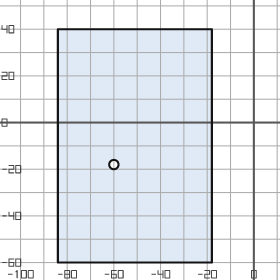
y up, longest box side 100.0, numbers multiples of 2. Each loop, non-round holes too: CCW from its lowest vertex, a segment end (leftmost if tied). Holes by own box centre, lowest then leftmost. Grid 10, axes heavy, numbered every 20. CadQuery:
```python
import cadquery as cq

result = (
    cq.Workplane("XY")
    .moveTo(-84.0, -60.0)
    .lineTo(-18.0, -60.0)
    .lineTo(-18.0, 40.0)
    .lineTo(-84.0, 40.0)
    .close()
    .moveTo(-60.0, -18.0)
    .circle(2.0)
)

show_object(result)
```